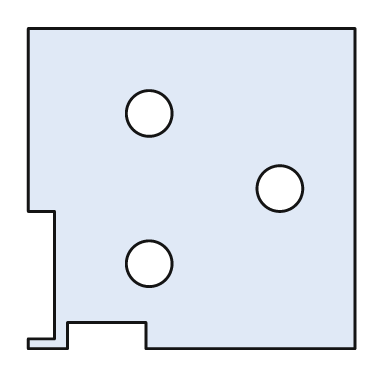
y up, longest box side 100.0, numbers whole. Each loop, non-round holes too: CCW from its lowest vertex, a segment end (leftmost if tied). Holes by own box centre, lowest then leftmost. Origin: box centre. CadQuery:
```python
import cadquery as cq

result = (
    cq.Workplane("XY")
    .moveTo(-50.0, -49.0)
    .lineTo(-38.0, -49.0)
    .lineTo(-38.0, -41.0)
    .lineTo(-14.0, -41.0)
    .lineTo(-14.0, -49.0)
    .lineTo(50.0, -49.0)
    .lineTo(50.0, 49.0)
    .lineTo(-50.0, 49.0)
    .lineTo(-50.0, -7.0)
    .lineTo(-42.0, -7.0)
    .lineTo(-42.0, -46.0)
    .lineTo(-50.0, -46.0)
    .close()
    .moveTo(-13.0, -23.0)
    .circle(7.0)
    .moveTo(27.0, 0.0)
    .circle(7.0)
    .moveTo(-13.0, 23.0)
    .circle(7.0)
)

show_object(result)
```